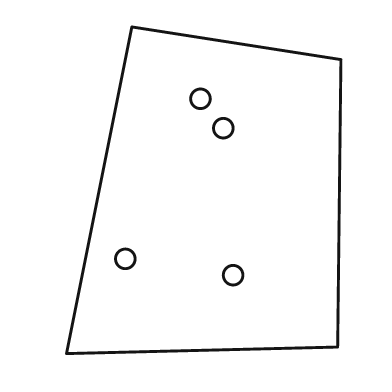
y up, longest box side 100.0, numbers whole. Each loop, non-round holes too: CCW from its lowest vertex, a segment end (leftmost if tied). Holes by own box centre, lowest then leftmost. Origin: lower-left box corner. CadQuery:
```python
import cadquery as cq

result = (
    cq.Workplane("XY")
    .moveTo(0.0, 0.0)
    .lineTo(83.0, 2.0)
    .lineTo(84.0, 90.0)
    .lineTo(20.0, 100.0)
    .close()
    .moveTo(51.0, 24.0)
    .circle(3.0)
    .moveTo(18.0, 29.0)
    .circle(3.0)
    .moveTo(48.0, 69.0)
    .circle(3.0)
    .moveTo(41.0, 78.0)
    .circle(3.0)
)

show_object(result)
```